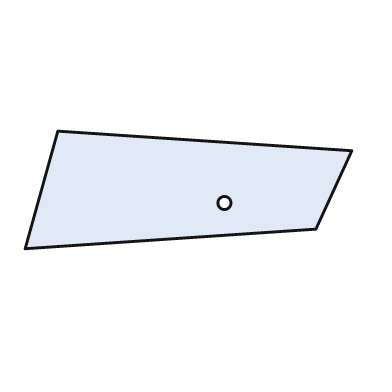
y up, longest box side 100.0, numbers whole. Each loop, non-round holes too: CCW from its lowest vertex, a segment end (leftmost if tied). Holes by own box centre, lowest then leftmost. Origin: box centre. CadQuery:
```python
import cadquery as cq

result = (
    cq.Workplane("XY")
    .moveTo(-50.0, -18.0)
    .lineTo(39.0, -12.0)
    .lineTo(50.0, 12.0)
    .lineTo(-40.0, 18.0)
    .close()
    .moveTo(11.0, -4.0)
    .circle(2.0)
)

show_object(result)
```